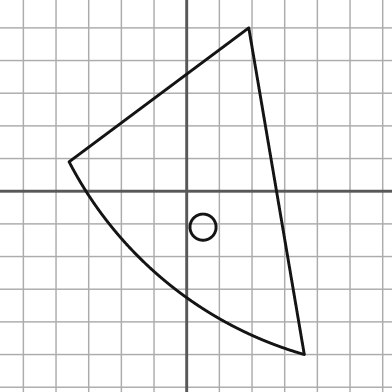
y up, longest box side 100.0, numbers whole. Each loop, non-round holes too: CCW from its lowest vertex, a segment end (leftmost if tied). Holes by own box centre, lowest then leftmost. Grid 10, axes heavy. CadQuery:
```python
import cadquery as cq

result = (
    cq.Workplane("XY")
    .moveTo(36.0, -50.0)
    .lineTo(19.0, 50.0)
    .lineTo(-36.0, 9.0)
    .threePointArc((-6.0, -28.0), (36.0, -50.0))
    .close()
    .moveTo(5.0, -11.0)
    .circle(4.0)
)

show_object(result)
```